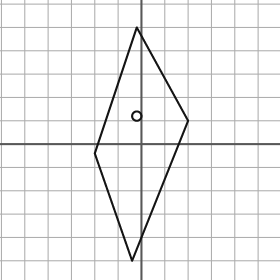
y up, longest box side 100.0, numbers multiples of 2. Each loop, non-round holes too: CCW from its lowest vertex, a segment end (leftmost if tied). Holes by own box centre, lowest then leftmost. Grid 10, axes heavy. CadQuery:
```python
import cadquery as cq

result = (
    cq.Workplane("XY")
    .moveTo(-4.0, -50.0)
    .lineTo(20.0, 10.0)
    .lineTo(-2.0, 50.0)
    .lineTo(-20.0, -4.0)
    .close()
    .moveTo(-2.0, 12.0)
    .circle(2.0)
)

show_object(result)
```